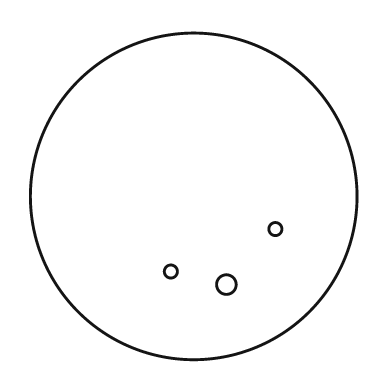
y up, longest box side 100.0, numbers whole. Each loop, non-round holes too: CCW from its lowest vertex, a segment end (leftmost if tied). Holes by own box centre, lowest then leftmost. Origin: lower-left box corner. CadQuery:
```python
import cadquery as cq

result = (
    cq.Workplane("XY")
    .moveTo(50.0, 50.0)
    .circle(50.0)
    .moveTo(60.0, 23.0)
    .circle(3.0)
    .moveTo(43.0, 27.0)
    .circle(2.0)
    .moveTo(75.0, 40.0)
    .circle(2.0)
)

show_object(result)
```